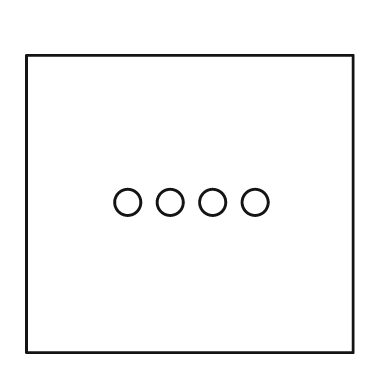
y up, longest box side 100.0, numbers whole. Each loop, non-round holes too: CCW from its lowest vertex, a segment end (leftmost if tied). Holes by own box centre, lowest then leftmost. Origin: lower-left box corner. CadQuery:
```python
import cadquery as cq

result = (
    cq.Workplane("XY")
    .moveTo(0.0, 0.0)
    .lineTo(100.0, 0.0)
    .lineTo(100.0, 91.0)
    .lineTo(0.0, 91.0)
    .close()
    .moveTo(31.0, 46.0)
    .circle(4.0)
    .moveTo(44.0, 46.0)
    .circle(4.0)
    .moveTo(57.0, 46.0)
    .circle(4.0)
    .moveTo(70.0, 46.0)
    .circle(4.0)
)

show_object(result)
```